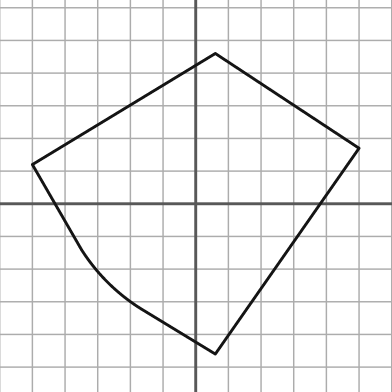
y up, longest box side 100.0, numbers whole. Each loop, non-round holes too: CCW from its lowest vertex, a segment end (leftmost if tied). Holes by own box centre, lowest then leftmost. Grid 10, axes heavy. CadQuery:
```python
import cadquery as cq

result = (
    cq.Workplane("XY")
    .moveTo(6.0, -46.0)
    .lineTo(50.0, 17.0)
    .lineTo(6.0, 46.0)
    .lineTo(-50.0, 12.0)
    .lineTo(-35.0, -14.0)
    .threePointArc((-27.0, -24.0), (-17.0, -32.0))
    .close()
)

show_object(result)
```